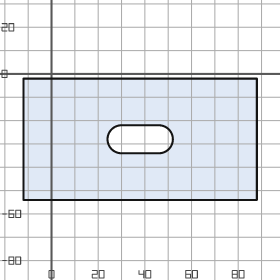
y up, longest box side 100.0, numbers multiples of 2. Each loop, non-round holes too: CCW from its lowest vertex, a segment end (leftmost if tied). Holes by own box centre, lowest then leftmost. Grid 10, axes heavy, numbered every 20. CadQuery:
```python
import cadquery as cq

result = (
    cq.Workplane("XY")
    .moveTo(-12.0, -54.0)
    .lineTo(88.0, -54.0)
    .lineTo(88.0, -2.0)
    .lineTo(-12.0, -2.0)
    .close()
    .moveTo(30.0, -34.0)
    .lineTo(46.0, -34.0)
    .threePointArc((52.0, -28.0), (46.0, -22.0))
    .lineTo(30.0, -22.0)
    .threePointArc((24.0, -28.0), (30.0, -34.0))
    .close()
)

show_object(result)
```